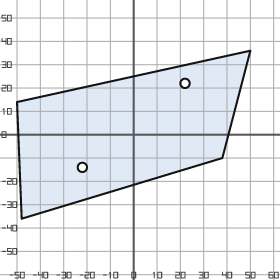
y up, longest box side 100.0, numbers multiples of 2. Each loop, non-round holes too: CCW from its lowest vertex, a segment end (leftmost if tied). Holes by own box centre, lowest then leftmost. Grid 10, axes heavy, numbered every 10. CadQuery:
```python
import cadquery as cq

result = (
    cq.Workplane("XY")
    .moveTo(-48.0, -36.0)
    .lineTo(38.0, -10.0)
    .lineTo(50.0, 36.0)
    .lineTo(-50.0, 14.0)
    .close()
    .moveTo(-22.0, -14.0)
    .circle(2.0)
    .moveTo(22.0, 22.0)
    .circle(2.0)
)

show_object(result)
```